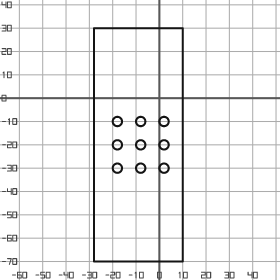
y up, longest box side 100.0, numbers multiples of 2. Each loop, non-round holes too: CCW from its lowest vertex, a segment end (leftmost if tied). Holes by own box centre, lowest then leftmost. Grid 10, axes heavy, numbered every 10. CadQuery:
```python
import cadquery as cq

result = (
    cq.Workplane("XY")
    .moveTo(-28.0, -70.0)
    .lineTo(10.0, -70.0)
    .lineTo(10.0, 30.0)
    .lineTo(-28.0, 30.0)
    .close()
    .moveTo(-18.0, -30.0)
    .circle(2.0)
    .moveTo(-8.0, -30.0)
    .circle(2.0)
    .moveTo(2.0, -30.0)
    .circle(2.0)
    .moveTo(-18.0, -20.0)
    .circle(2.0)
    .moveTo(-8.0, -20.0)
    .circle(2.0)
    .moveTo(2.0, -20.0)
    .circle(2.0)
    .moveTo(-18.0, -10.0)
    .circle(2.0)
    .moveTo(-8.0, -10.0)
    .circle(2.0)
    .moveTo(2.0, -10.0)
    .circle(2.0)
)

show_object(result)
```